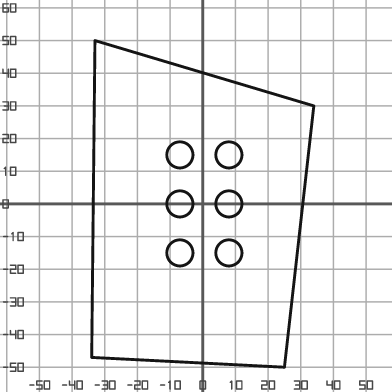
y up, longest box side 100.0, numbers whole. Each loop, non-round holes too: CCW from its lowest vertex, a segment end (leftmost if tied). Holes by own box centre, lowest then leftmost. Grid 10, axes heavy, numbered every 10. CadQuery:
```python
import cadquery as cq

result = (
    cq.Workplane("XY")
    .moveTo(25.0, -50.0)
    .lineTo(34.0, 30.0)
    .lineTo(-33.0, 50.0)
    .lineTo(-34.0, -47.0)
    .close()
    .moveTo(-7.0, -15.0)
    .circle(4.0)
    .moveTo(8.0, -15.0)
    .circle(4.0)
    .moveTo(-7.0, 0.0)
    .circle(4.0)
    .moveTo(8.0, 0.0)
    .circle(4.0)
    .moveTo(-7.0, 15.0)
    .circle(4.0)
    .moveTo(8.0, 15.0)
    .circle(4.0)
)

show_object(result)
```